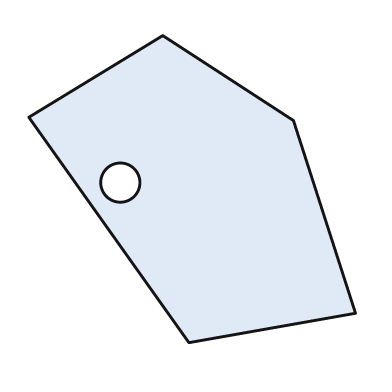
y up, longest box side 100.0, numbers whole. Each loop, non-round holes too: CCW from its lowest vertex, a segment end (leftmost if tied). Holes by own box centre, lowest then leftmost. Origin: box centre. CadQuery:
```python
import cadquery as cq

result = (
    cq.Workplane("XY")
    .moveTo(-1.0, -47.0)
    .lineTo(50.0, -38.0)
    .lineTo(31.0, 21.0)
    .lineTo(-9.0, 47.0)
    .lineTo(-50.0, 22.0)
    .close()
    .moveTo(-22.0, 2.0)
    .circle(6.0)
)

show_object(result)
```